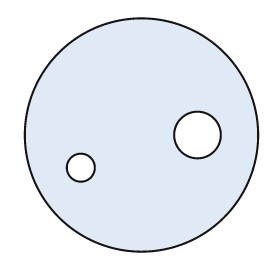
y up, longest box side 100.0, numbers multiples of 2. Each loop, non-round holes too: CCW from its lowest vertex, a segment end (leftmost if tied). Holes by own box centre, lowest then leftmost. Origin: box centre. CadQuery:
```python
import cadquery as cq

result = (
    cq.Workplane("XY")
    .moveTo(0.0, 0.0)
    .circle(50.0)
    .moveTo(-26.0, -14.0)
    .circle(6.0)
    .moveTo(24.0, 0.0)
    .circle(10.0)
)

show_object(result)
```